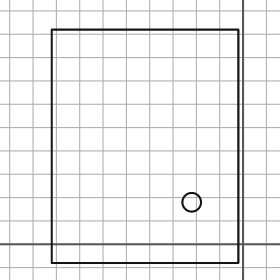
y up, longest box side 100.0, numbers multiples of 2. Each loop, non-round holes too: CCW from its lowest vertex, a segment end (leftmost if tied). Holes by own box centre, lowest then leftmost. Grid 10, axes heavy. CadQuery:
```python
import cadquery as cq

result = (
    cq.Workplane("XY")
    .moveTo(-82.0, -8.0)
    .lineTo(-2.0, -8.0)
    .lineTo(-2.0, 92.0)
    .lineTo(-82.0, 92.0)
    .close()
    .moveTo(-22.0, 18.0)
    .circle(4.0)
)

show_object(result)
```